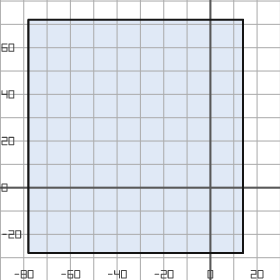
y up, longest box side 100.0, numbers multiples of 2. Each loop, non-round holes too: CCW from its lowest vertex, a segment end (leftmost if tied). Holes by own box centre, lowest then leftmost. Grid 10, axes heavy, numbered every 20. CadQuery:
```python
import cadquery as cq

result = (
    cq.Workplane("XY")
    .moveTo(-78.0, -28.0)
    .lineTo(14.0, -28.0)
    .lineTo(14.0, 72.0)
    .lineTo(-78.0, 72.0)
    .close()
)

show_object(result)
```